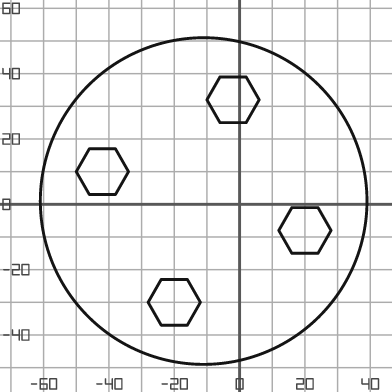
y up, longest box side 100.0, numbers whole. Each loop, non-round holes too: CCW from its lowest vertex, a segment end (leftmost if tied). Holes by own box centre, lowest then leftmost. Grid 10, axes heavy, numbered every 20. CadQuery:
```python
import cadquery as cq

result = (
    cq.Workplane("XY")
    .moveTo(-11.0, 1.0)
    .circle(50.0)
    .moveTo(-24.0, -37.0)
    .lineTo(-16.0, -37.0)
    .lineTo(-12.0, -30.0)
    .lineTo(-16.0, -23.0)
    .lineTo(-24.0, -23.0)
    .lineTo(-28.0, -30.0)
    .close()
    .moveTo(16.0, -15.0)
    .lineTo(24.0, -15.0)
    .lineTo(28.0, -8.0)
    .lineTo(24.0, -1.0)
    .lineTo(16.0, -1.0)
    .lineTo(12.0, -8.0)
    .close()
    .moveTo(-46.0, 3.0)
    .lineTo(-38.0, 3.0)
    .lineTo(-34.0, 10.0)
    .lineTo(-38.0, 17.0)
    .lineTo(-46.0, 17.0)
    .lineTo(-50.0, 10.0)
    .close()
    .moveTo(-6.0, 25.0)
    .lineTo(2.0, 25.0)
    .lineTo(6.0, 32.0)
    .lineTo(2.0, 39.0)
    .lineTo(-6.0, 39.0)
    .lineTo(-10.0, 32.0)
    .close()
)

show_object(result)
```